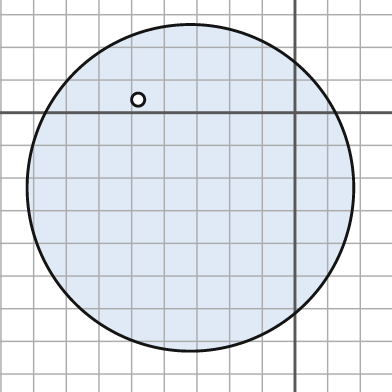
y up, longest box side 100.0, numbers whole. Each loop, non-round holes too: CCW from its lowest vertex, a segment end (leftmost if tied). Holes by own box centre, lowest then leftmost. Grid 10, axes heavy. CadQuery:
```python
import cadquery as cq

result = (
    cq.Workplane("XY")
    .moveTo(-32.0, -23.0)
    .circle(50.0)
    .moveTo(-48.0, 4.0)
    .circle(2.0)
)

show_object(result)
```